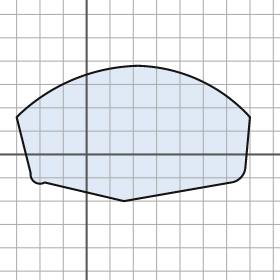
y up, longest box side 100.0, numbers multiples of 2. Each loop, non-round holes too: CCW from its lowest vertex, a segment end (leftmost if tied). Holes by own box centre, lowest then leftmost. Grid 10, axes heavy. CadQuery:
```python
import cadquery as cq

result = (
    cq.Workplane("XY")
    .moveTo(16.0, -20.0)
    .lineTo(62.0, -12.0)
    .threePointArc((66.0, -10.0), (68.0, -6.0))
    .lineTo(70.0, 16.0)
    .threePointArc((48.0, 32.0), (22.0, 38.0))
    .threePointArc((-6.0, 32.0), (-30.0, 16.0))
    .lineTo(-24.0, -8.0)
    .threePointArc((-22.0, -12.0), (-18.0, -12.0))
    .close()
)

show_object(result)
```